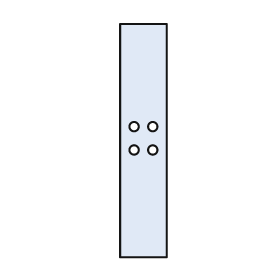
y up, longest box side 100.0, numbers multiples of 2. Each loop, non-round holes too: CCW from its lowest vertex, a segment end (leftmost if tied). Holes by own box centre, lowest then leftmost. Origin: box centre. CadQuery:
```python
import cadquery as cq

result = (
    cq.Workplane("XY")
    .moveTo(-10.0, -50.0)
    .lineTo(10.0, -50.0)
    .lineTo(10.0, 50.0)
    .lineTo(-10.0, 50.0)
    .close()
    .moveTo(-4.0, -4.0)
    .circle(2.0)
    .moveTo(4.0, -4.0)
    .circle(2.0)
    .moveTo(-4.0, 6.0)
    .circle(2.0)
    .moveTo(4.0, 6.0)
    .circle(2.0)
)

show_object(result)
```